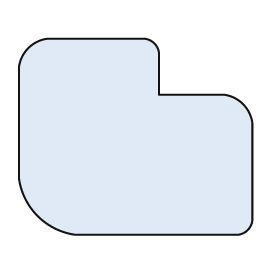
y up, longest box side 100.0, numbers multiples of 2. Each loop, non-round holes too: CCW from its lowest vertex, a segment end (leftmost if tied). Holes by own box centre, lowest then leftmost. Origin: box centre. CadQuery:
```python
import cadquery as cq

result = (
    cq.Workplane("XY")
    .moveTo(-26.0, -42.0)
    .lineTo(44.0, -42.0)
    .threePointArc((48.0, -40.0), (50.0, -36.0))
    .lineTo(50.0, 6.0)
    .threePointArc((46.0, 14.0), (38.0, 18.0))
    .lineTo(10.0, 18.0)
    .lineTo(10.0, 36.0)
    .threePointArc((8.0, 40.0), (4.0, 42.0))
    .lineTo(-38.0, 42.0)
    .threePointArc((-46.0, 38.0), (-50.0, 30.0))
    .lineTo(-50.0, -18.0)
    .threePointArc((-42.0, -34.0), (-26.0, -42.0))
    .close()
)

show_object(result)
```